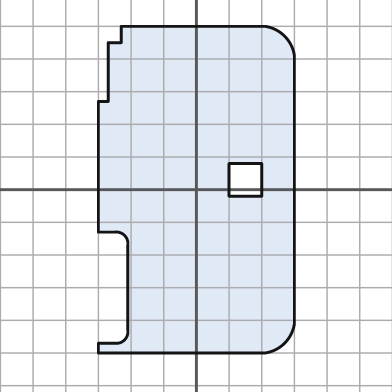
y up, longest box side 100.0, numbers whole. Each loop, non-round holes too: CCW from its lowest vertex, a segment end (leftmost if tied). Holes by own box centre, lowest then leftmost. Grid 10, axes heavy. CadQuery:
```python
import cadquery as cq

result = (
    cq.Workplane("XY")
    .moveTo(-30.0, -50.0)
    .lineTo(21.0, -50.0)
    .threePointArc((27.0, -47.0), (30.0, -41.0))
    .lineTo(30.0, 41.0)
    .threePointArc((27.0, 47.0), (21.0, 50.0))
    .lineTo(-23.0, 50.0)
    .lineTo(-23.0, 45.0)
    .lineTo(-27.0, 45.0)
    .lineTo(-27.0, 27.0)
    .lineTo(-30.0, 27.0)
    .lineTo(-30.0, -13.0)
    .lineTo(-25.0, -13.0)
    .threePointArc((-22.0, -14.0), (-21.0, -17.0))
    .lineTo(-21.0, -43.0)
    .threePointArc((-22.0, -46.0), (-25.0, -47.0))
    .lineTo(-30.0, -47.0)
    .close()
    .moveTo(10.0, -2.0)
    .lineTo(20.0, -2.0)
    .lineTo(20.0, 8.0)
    .lineTo(10.0, 8.0)
    .close()
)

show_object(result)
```